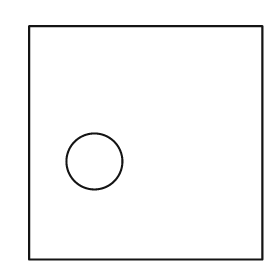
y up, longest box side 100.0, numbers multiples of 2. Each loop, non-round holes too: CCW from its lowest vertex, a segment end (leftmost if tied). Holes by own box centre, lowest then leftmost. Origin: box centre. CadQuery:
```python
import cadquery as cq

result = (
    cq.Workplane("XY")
    .moveTo(-50.0, -50.0)
    .lineTo(50.0, -50.0)
    .lineTo(50.0, 50.0)
    .lineTo(-50.0, 50.0)
    .close()
    .moveTo(-22.0, -8.0)
    .circle(12.0)
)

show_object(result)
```